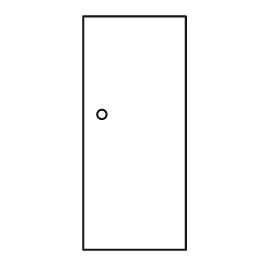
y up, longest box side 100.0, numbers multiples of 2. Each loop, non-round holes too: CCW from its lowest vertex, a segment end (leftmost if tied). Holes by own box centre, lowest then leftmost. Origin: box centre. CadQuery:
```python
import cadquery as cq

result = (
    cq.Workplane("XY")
    .moveTo(-22.0, -50.0)
    .lineTo(22.0, -50.0)
    .lineTo(22.0, 50.0)
    .lineTo(-22.0, 50.0)
    .close()
    .moveTo(-14.0, 8.0)
    .circle(2.0)
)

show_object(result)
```